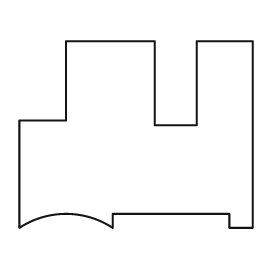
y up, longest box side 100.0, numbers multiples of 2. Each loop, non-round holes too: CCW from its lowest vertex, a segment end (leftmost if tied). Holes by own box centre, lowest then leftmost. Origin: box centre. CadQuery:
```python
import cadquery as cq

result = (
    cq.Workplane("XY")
    .moveTo(-50.0, -40.0)
    .threePointArc((-30.0, -34.0), (-10.0, -40.0))
    .lineTo(-10.0, -34.0)
    .lineTo(40.0, -34.0)
    .lineTo(40.0, -40.0)
    .lineTo(50.0, -40.0)
    .lineTo(50.0, 40.0)
    .lineTo(26.0, 40.0)
    .lineTo(26.0, 4.0)
    .lineTo(8.0, 4.0)
    .lineTo(8.0, 40.0)
    .lineTo(-30.0, 40.0)
    .lineTo(-30.0, 6.0)
    .lineTo(-50.0, 6.0)
    .close()
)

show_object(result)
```